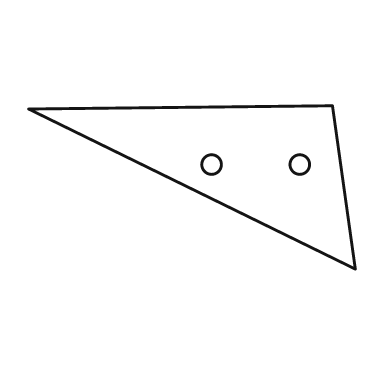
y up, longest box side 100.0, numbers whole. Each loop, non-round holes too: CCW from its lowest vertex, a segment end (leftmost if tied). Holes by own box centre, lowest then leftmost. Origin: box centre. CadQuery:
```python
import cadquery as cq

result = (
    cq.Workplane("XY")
    .moveTo(50.0, -25.0)
    .lineTo(43.0, 25.0)
    .lineTo(-50.0, 24.0)
    .close()
    .moveTo(6.0, 7.0)
    .circle(3.0)
    .moveTo(33.0, 7.0)
    .circle(3.0)
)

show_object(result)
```